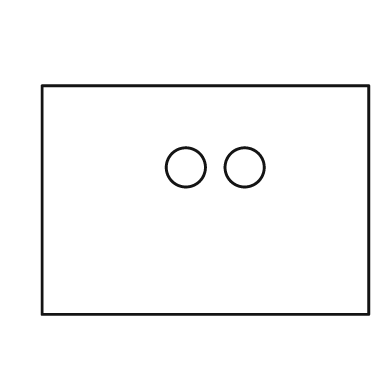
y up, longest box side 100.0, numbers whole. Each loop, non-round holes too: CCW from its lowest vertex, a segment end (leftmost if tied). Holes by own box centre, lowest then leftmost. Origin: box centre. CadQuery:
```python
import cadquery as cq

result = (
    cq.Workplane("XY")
    .moveTo(-50.0, -35.0)
    .lineTo(50.0, -35.0)
    .lineTo(50.0, 35.0)
    .lineTo(-50.0, 35.0)
    .close()
    .moveTo(-6.0, 10.0)
    .circle(6.0)
    .moveTo(12.0, 10.0)
    .circle(6.0)
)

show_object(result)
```